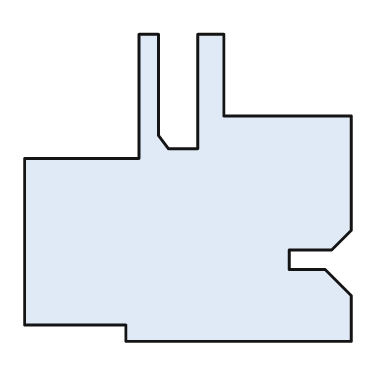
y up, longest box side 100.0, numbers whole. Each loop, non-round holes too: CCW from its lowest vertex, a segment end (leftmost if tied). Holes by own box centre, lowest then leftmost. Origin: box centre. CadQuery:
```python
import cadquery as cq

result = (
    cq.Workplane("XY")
    .moveTo(-19.0, -47.0)
    .lineTo(50.0, -47.0)
    .lineTo(50.0, -33.0)
    .lineTo(42.0, -25.0)
    .lineTo(31.0, -25.0)
    .lineTo(31.0, -19.0)
    .lineTo(44.0, -19.0)
    .lineTo(50.0, -13.0)
    .lineTo(50.0, 22.0)
    .lineTo(11.0, 22.0)
    .lineTo(11.0, 47.0)
    .lineTo(3.0, 47.0)
    .lineTo(3.0, 12.0)
    .lineTo(-6.0, 12.0)
    .lineTo(-9.0, 16.0)
    .lineTo(-9.0, 47.0)
    .lineTo(-15.0, 47.0)
    .lineTo(-15.0, 9.0)
    .lineTo(-50.0, 9.0)
    .lineTo(-50.0, -42.0)
    .lineTo(-19.0, -42.0)
    .close()
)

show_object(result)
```